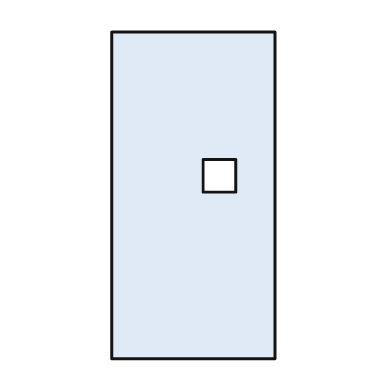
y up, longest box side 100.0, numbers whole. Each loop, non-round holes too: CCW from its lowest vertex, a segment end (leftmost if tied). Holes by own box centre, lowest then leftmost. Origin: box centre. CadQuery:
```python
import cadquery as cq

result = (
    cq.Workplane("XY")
    .moveTo(-25.0, -50.0)
    .lineTo(25.0, -50.0)
    .lineTo(25.0, 50.0)
    .lineTo(-25.0, 50.0)
    .close()
    .moveTo(3.0, 1.0)
    .lineTo(13.0, 1.0)
    .lineTo(13.0, 11.0)
    .lineTo(3.0, 11.0)
    .close()
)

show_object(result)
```